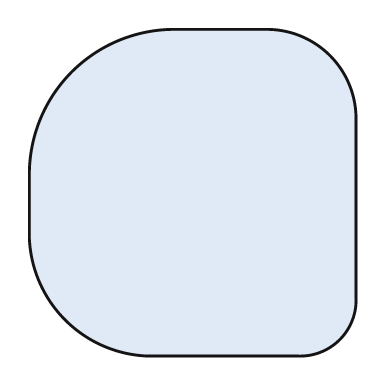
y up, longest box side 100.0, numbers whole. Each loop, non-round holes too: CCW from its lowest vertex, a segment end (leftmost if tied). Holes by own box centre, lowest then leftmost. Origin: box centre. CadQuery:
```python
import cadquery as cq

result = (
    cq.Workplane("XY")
    .moveTo(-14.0, -50.0)
    .lineTo(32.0, -50.0)
    .threePointArc((45.0, -45.0), (50.0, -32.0))
    .lineTo(50.0, 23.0)
    .threePointArc((42.0, 42.0), (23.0, 50.0))
    .lineTo(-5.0, 50.0)
    .threePointArc((-37.0, 37.0), (-50.0, 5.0))
    .lineTo(-50.0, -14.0)
    .threePointArc((-39.0, -39.0), (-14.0, -50.0))
    .close()
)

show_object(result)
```